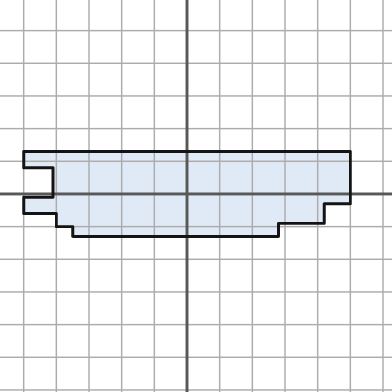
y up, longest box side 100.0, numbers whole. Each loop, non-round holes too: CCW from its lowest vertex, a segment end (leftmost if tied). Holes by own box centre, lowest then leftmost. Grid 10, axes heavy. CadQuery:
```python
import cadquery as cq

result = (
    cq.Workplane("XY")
    .moveTo(-35.0, -13.0)
    .lineTo(28.0, -13.0)
    .lineTo(28.0, -9.0)
    .lineTo(42.0, -9.0)
    .lineTo(42.0, -3.0)
    .lineTo(50.0, -3.0)
    .lineTo(50.0, 13.0)
    .lineTo(-50.0, 13.0)
    .lineTo(-50.0, 8.0)
    .lineTo(-41.0, 8.0)
    .lineTo(-41.0, -1.0)
    .lineTo(-50.0, -1.0)
    .lineTo(-50.0, -6.0)
    .lineTo(-40.0, -6.0)
    .lineTo(-40.0, -10.0)
    .lineTo(-35.0, -10.0)
    .close()
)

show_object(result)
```